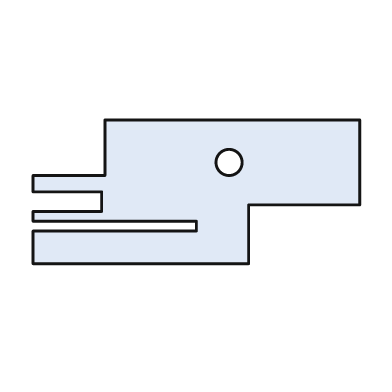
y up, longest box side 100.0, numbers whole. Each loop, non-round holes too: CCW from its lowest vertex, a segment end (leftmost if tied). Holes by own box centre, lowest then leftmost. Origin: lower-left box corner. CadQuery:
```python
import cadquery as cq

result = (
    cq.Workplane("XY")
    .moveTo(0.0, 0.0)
    .lineTo(66.0, 0.0)
    .lineTo(66.0, 18.0)
    .lineTo(100.0, 18.0)
    .lineTo(100.0, 44.0)
    .lineTo(22.0, 44.0)
    .lineTo(22.0, 27.0)
    .lineTo(0.0, 27.0)
    .lineTo(0.0, 22.0)
    .lineTo(21.0, 22.0)
    .lineTo(21.0, 16.0)
    .lineTo(0.0, 16.0)
    .lineTo(0.0, 13.0)
    .lineTo(50.0, 13.0)
    .lineTo(50.0, 10.0)
    .lineTo(0.0, 10.0)
    .close()
    .moveTo(60.0, 31.0)
    .circle(4.0)
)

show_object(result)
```